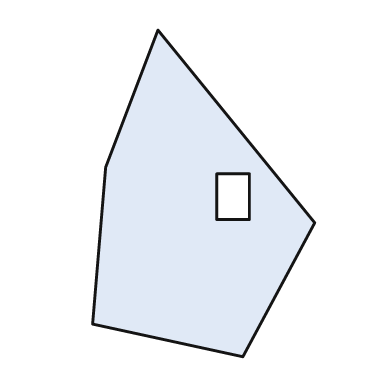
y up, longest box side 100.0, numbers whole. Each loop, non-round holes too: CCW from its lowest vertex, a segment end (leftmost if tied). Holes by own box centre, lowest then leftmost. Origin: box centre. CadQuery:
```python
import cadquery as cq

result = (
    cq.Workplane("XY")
    .moveTo(12.0, -50.0)
    .lineTo(34.0, -9.0)
    .lineTo(-14.0, 50.0)
    .lineTo(-30.0, 8.0)
    .lineTo(-34.0, -40.0)
    .close()
    .moveTo(4.0, -8.0)
    .lineTo(14.0, -8.0)
    .lineTo(14.0, 6.0)
    .lineTo(4.0, 6.0)
    .close()
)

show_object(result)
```